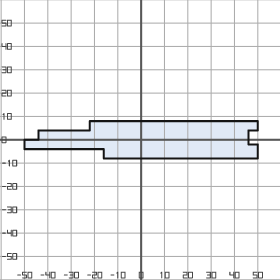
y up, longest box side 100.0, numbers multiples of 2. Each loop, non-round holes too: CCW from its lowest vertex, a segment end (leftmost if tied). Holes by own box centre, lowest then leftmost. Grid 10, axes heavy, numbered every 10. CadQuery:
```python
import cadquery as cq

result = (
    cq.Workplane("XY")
    .moveTo(-16.0, -8.0)
    .lineTo(50.0, -8.0)
    .lineTo(50.0, -2.0)
    .lineTo(46.0, -2.0)
    .lineTo(46.0, 4.0)
    .lineTo(50.0, 4.0)
    .lineTo(50.0, 8.0)
    .lineTo(-22.0, 8.0)
    .lineTo(-22.0, 4.0)
    .lineTo(-44.0, 4.0)
    .lineTo(-44.0, 0.0)
    .lineTo(-50.0, 0.0)
    .lineTo(-50.0, -4.0)
    .lineTo(-16.0, -4.0)
    .close()
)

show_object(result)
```